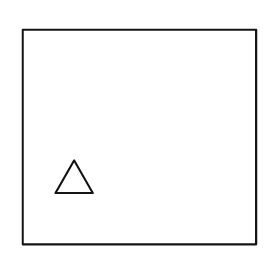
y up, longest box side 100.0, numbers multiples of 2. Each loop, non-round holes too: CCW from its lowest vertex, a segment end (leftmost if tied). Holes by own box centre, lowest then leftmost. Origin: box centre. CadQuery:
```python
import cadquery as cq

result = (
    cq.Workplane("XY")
    .moveTo(-50.0, -46.0)
    .lineTo(50.0, -46.0)
    .lineTo(50.0, 46.0)
    .lineTo(-50.0, 46.0)
    .close()
    .moveTo(-36.0, -24.0)
    .lineTo(-20.0, -24.0)
    .lineTo(-28.0, -10.0)
    .close()
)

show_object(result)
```